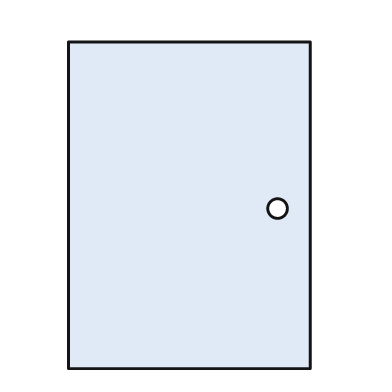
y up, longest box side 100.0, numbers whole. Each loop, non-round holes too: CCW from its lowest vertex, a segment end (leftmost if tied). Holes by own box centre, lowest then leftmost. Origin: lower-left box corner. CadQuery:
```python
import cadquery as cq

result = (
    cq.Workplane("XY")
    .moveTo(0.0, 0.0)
    .lineTo(74.0, 0.0)
    .lineTo(74.0, 100.0)
    .lineTo(0.0, 100.0)
    .close()
    .moveTo(64.0, 49.0)
    .circle(3.0)
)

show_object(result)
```